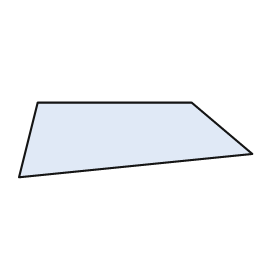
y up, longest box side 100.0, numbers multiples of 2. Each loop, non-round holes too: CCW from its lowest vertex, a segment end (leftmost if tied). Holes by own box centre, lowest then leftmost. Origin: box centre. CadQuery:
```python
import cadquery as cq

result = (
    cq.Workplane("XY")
    .moveTo(-50.0, -16.0)
    .lineTo(50.0, -6.0)
    .lineTo(24.0, 16.0)
    .lineTo(-42.0, 16.0)
    .close()
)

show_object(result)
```